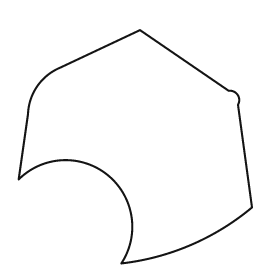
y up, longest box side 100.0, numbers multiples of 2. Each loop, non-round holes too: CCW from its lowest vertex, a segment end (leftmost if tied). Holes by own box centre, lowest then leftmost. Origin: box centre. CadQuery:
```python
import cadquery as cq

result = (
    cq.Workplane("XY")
    .moveTo(-6.0, -50.0)
    .threePointArc((24.0, -42.0), (50.0, -26.0))
    .lineTo(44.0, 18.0)
    .threePointArc((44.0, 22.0), (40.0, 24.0))
    .lineTo(2.0, 50.0)
    .lineTo(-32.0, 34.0)
    .threePointArc((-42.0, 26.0), (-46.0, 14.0))
    .lineTo(-50.0, -14.0)
    .threePointArc((-12.0, -12.0), (-6.0, -50.0))
    .close()
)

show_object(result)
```